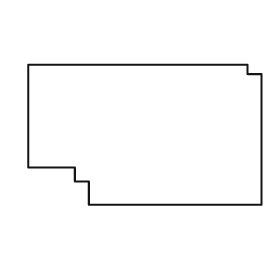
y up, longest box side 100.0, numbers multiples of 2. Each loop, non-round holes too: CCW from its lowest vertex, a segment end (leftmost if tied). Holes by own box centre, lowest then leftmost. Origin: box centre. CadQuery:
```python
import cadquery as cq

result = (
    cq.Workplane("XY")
    .moveTo(-24.0, -30.0)
    .lineTo(50.0, -30.0)
    .lineTo(50.0, 26.0)
    .lineTo(44.0, 26.0)
    .lineTo(44.0, 30.0)
    .lineTo(-50.0, 30.0)
    .lineTo(-50.0, -14.0)
    .lineTo(-30.0, -14.0)
    .lineTo(-30.0, -20.0)
    .lineTo(-24.0, -20.0)
    .close()
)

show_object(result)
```